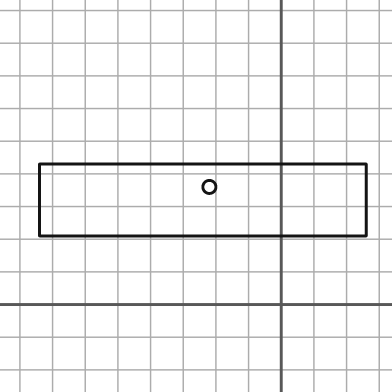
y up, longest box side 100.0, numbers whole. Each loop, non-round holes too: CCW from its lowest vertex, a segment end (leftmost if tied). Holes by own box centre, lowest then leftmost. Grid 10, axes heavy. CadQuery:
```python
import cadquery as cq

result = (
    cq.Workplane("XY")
    .moveTo(-74.0, 21.0)
    .lineTo(26.0, 21.0)
    .lineTo(26.0, 43.0)
    .lineTo(-74.0, 43.0)
    .close()
    .moveTo(-22.0, 36.0)
    .circle(2.0)
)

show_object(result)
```